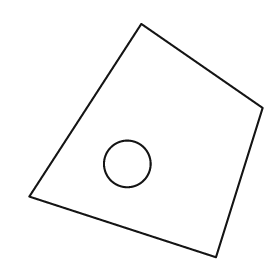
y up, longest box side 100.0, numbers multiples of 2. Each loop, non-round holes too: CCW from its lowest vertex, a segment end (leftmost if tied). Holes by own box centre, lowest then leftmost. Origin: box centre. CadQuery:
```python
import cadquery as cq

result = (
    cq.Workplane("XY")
    .moveTo(30.0, -50.0)
    .lineTo(50.0, 14.0)
    .lineTo(-2.0, 50.0)
    .lineTo(-50.0, -24.0)
    .close()
    .moveTo(-8.0, -10.0)
    .circle(10.0)
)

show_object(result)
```